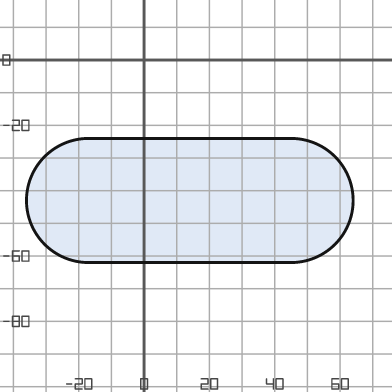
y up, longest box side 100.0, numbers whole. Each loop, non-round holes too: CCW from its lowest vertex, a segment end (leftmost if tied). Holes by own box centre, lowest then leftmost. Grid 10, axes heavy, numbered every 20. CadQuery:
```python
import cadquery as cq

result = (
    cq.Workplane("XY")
    .moveTo(-17.0, -62.0)
    .lineTo(45.0, -62.0)
    .threePointArc((64.0, -43.0), (45.0, -24.0))
    .lineTo(-17.0, -24.0)
    .threePointArc((-36.0, -43.0), (-17.0, -62.0))
    .close()
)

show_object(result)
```